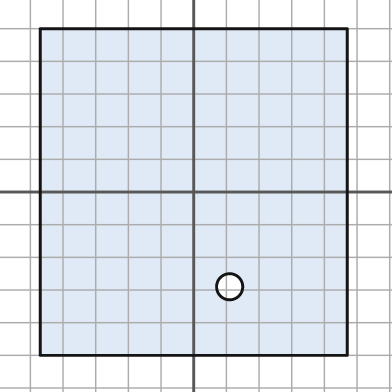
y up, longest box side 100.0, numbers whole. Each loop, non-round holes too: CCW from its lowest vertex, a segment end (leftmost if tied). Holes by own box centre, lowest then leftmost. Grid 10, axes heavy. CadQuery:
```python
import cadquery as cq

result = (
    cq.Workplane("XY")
    .moveTo(-47.0, -50.0)
    .lineTo(47.0, -50.0)
    .lineTo(47.0, 50.0)
    .lineTo(-47.0, 50.0)
    .close()
    .moveTo(11.0, -29.0)
    .circle(4.0)
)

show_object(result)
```